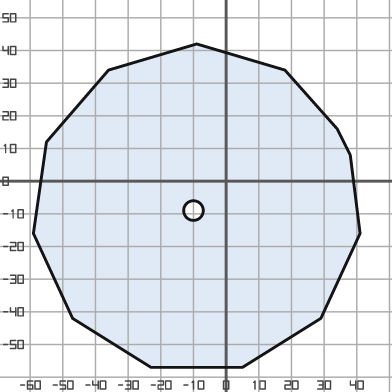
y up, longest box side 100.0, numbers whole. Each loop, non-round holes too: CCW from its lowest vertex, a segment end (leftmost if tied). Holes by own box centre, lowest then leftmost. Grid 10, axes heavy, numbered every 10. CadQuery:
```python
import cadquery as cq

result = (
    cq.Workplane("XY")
    .moveTo(-23.0, -57.0)
    .lineTo(5.0, -57.0)
    .lineTo(29.0, -42.0)
    .lineTo(41.0, -16.0)
    .lineTo(38.0, 8.0)
    .lineTo(34.0, 16.0)
    .lineTo(18.0, 34.0)
    .lineTo(-9.0, 42.0)
    .lineTo(-36.0, 34.0)
    .lineTo(-55.0, 12.0)
    .lineTo(-59.0, -16.0)
    .lineTo(-47.0, -42.0)
    .close()
    .moveTo(-10.0, -9.0)
    .circle(3.0)
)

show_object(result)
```